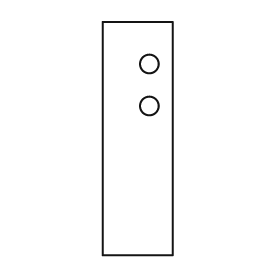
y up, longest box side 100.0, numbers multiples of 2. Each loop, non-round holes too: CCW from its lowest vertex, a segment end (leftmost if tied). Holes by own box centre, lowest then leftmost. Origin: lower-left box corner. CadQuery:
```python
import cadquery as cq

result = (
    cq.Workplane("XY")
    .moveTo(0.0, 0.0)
    .lineTo(30.0, 0.0)
    .lineTo(30.0, 100.0)
    .lineTo(0.0, 100.0)
    .close()
    .moveTo(20.0, 64.0)
    .circle(4.0)
    .moveTo(20.0, 82.0)
    .circle(4.0)
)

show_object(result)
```